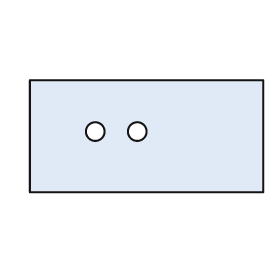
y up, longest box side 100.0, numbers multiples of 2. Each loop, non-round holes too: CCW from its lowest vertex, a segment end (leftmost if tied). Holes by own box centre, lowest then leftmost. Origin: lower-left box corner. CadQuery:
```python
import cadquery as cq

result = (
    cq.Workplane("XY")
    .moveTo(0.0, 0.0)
    .lineTo(100.0, 0.0)
    .lineTo(100.0, 48.0)
    .lineTo(0.0, 48.0)
    .close()
    .moveTo(28.0, 26.0)
    .circle(4.0)
    .moveTo(46.0, 26.0)
    .circle(4.0)
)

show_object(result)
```